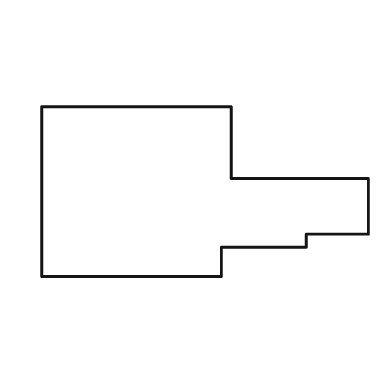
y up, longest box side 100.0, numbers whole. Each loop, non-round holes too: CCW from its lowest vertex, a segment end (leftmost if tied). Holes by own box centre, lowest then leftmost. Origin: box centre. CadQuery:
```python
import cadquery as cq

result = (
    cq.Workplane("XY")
    .moveTo(-50.0, -26.0)
    .lineTo(5.0, -26.0)
    .lineTo(5.0, -17.0)
    .lineTo(31.0, -17.0)
    .lineTo(31.0, -13.0)
    .lineTo(50.0, -13.0)
    .lineTo(50.0, 4.0)
    .lineTo(8.0, 4.0)
    .lineTo(8.0, 26.0)
    .lineTo(-50.0, 26.0)
    .close()
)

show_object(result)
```